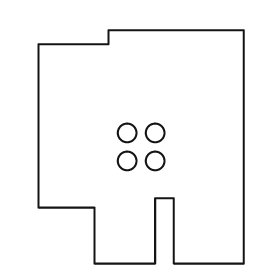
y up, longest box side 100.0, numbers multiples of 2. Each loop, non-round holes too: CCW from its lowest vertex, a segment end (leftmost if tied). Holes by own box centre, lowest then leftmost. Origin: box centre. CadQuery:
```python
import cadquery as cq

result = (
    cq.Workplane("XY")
    .moveTo(-20.0, -50.0)
    .lineTo(6.0, -50.0)
    .lineTo(6.0, -22.0)
    .lineTo(14.0, -22.0)
    .lineTo(14.0, -50.0)
    .lineTo(44.0, -50.0)
    .lineTo(44.0, 50.0)
    .lineTo(-14.0, 50.0)
    .lineTo(-14.0, 44.0)
    .lineTo(-44.0, 44.0)
    .lineTo(-44.0, -26.0)
    .lineTo(-20.0, -26.0)
    .close()
    .moveTo(-6.0, -6.0)
    .circle(4.0)
    .moveTo(6.0, -6.0)
    .circle(4.0)
    .moveTo(-6.0, 6.0)
    .circle(4.0)
    .moveTo(6.0, 6.0)
    .circle(4.0)
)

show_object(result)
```